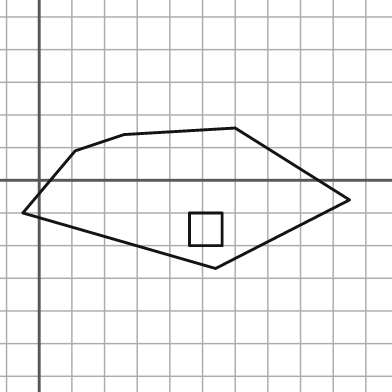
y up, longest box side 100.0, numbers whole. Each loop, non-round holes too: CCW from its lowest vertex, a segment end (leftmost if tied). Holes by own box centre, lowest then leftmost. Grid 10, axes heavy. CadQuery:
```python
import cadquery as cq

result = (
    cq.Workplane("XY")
    .moveTo(54.0, -27.0)
    .lineTo(95.0, -6.0)
    .lineTo(60.0, 16.0)
    .lineTo(26.0, 14.0)
    .lineTo(11.0, 9.0)
    .lineTo(-5.0, -10.0)
    .close()
    .moveTo(46.0, -20.0)
    .lineTo(56.0, -20.0)
    .lineTo(56.0, -10.0)
    .lineTo(46.0, -10.0)
    .close()
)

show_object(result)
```